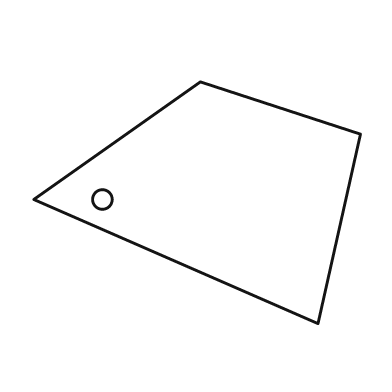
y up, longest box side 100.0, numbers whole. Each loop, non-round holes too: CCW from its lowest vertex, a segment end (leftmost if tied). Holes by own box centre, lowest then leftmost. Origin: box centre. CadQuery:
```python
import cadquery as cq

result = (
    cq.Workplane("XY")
    .moveTo(37.0, -37.0)
    .lineTo(50.0, 21.0)
    .lineTo(1.0, 37.0)
    .lineTo(-50.0, 1.0)
    .close()
    .moveTo(-29.0, 1.0)
    .circle(3.0)
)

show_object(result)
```